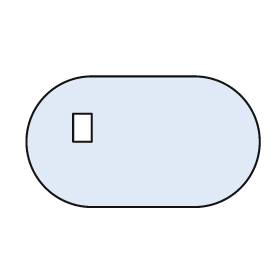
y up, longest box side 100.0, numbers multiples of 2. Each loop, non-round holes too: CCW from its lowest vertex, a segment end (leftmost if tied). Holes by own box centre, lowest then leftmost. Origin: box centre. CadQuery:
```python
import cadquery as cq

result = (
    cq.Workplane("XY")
    .moveTo(-22.0, -28.0)
    .lineTo(22.0, -28.0)
    .threePointArc((50.0, 0.0), (22.0, 28.0))
    .lineTo(-22.0, 28.0)
    .threePointArc((-50.0, 0.0), (-22.0, -28.0))
    .close()
    .moveTo(-30.0, 0.0)
    .lineTo(-22.0, 0.0)
    .lineTo(-22.0, 12.0)
    .lineTo(-30.0, 12.0)
    .close()
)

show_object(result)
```